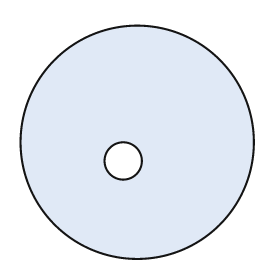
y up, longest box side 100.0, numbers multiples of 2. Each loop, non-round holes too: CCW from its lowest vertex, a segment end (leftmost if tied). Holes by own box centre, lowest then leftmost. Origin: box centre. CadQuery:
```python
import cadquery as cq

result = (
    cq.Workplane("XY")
    .moveTo(0.0, 0.0)
    .circle(50.0)
    .moveTo(-6.0, -8.0)
    .circle(8.0)
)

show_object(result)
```